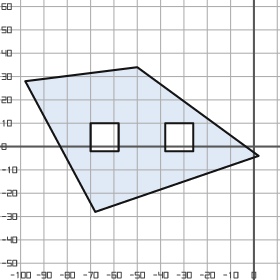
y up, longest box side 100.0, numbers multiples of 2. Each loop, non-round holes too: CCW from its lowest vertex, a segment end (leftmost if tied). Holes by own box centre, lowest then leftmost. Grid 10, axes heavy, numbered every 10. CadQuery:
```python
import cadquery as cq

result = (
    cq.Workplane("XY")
    .moveTo(-68.0, -28.0)
    .lineTo(2.0, -4.0)
    .lineTo(-50.0, 34.0)
    .lineTo(-98.0, 28.0)
    .close()
    .moveTo(-70.0, -2.0)
    .lineTo(-58.0, -2.0)
    .lineTo(-58.0, 10.0)
    .lineTo(-70.0, 10.0)
    .close()
    .moveTo(-38.0, -2.0)
    .lineTo(-26.0, -2.0)
    .lineTo(-26.0, 10.0)
    .lineTo(-38.0, 10.0)
    .close()
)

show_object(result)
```